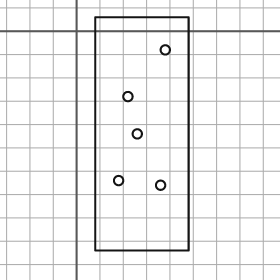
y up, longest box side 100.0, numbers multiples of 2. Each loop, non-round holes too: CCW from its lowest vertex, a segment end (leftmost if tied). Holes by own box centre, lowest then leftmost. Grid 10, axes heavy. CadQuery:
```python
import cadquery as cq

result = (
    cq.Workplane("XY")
    .moveTo(8.0, -94.0)
    .lineTo(48.0, -94.0)
    .lineTo(48.0, 6.0)
    .lineTo(8.0, 6.0)
    .close()
    .moveTo(36.0, -66.0)
    .circle(2.0)
    .moveTo(18.0, -64.0)
    .circle(2.0)
    .moveTo(26.0, -44.0)
    .circle(2.0)
    .moveTo(22.0, -28.0)
    .circle(2.0)
    .moveTo(38.0, -8.0)
    .circle(2.0)
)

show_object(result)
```